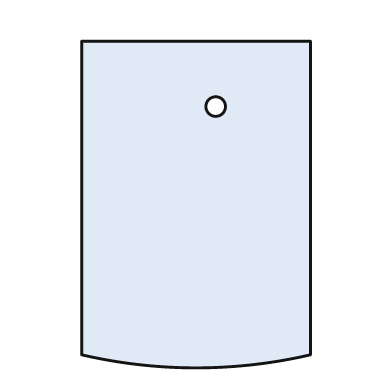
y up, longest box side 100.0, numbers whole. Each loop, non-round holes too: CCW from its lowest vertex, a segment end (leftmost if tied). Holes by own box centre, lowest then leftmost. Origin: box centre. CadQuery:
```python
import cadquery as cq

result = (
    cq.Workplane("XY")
    .moveTo(-35.0, -46.0)
    .threePointArc((0.0, -50.0), (35.0, -46.0))
    .lineTo(35.0, 50.0)
    .lineTo(-35.0, 50.0)
    .close()
    .moveTo(6.0, 30.0)
    .circle(3.0)
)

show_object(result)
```